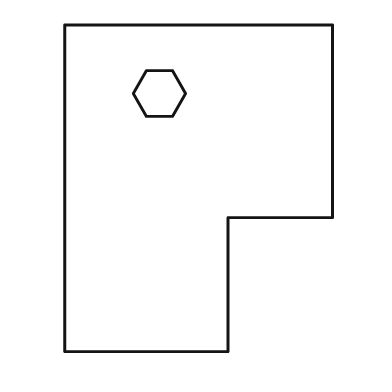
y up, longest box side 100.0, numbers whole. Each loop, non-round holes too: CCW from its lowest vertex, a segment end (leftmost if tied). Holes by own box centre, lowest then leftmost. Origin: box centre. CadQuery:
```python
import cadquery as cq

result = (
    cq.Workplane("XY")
    .moveTo(-41.0, -50.0)
    .lineTo(9.0, -50.0)
    .lineTo(9.0, -9.0)
    .lineTo(41.0, -9.0)
    .lineTo(41.0, 50.0)
    .lineTo(-41.0, 50.0)
    .close()
    .moveTo(-16.0, 22.0)
    .lineTo(-8.0, 22.0)
    .lineTo(-4.0, 29.0)
    .lineTo(-8.0, 36.0)
    .lineTo(-16.0, 36.0)
    .lineTo(-20.0, 29.0)
    .close()
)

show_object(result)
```